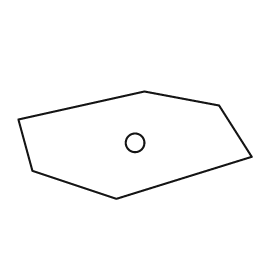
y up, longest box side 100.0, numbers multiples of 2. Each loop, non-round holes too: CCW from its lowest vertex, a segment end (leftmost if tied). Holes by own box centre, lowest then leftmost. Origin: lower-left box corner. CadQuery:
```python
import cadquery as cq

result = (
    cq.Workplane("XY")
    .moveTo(42.0, 0.0)
    .lineTo(100.0, 18.0)
    .lineTo(86.0, 40.0)
    .lineTo(54.0, 46.0)
    .lineTo(0.0, 34.0)
    .lineTo(6.0, 12.0)
    .close()
    .moveTo(50.0, 24.0)
    .circle(4.0)
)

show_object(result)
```